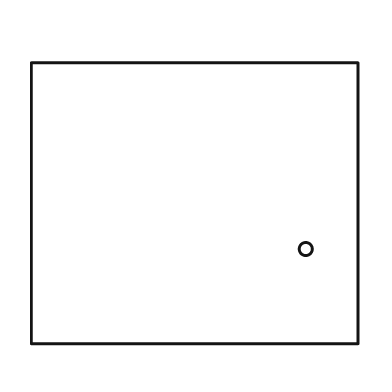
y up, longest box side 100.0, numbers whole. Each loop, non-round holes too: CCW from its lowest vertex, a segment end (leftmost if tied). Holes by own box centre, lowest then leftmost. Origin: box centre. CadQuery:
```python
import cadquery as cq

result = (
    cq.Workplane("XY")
    .moveTo(-50.0, -43.0)
    .lineTo(50.0, -43.0)
    .lineTo(50.0, 43.0)
    .lineTo(-50.0, 43.0)
    .close()
    .moveTo(34.0, -14.0)
    .circle(2.0)
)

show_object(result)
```